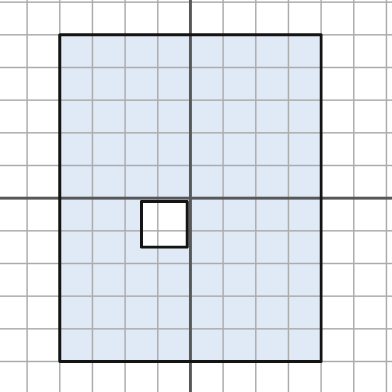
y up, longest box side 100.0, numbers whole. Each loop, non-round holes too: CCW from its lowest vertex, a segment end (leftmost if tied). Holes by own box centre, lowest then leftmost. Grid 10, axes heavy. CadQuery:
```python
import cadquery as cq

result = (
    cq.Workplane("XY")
    .moveTo(-40.0, -50.0)
    .lineTo(40.0, -50.0)
    .lineTo(40.0, 50.0)
    .lineTo(-40.0, 50.0)
    .close()
    .moveTo(-15.0, -15.0)
    .lineTo(-1.0, -15.0)
    .lineTo(-1.0, -1.0)
    .lineTo(-15.0, -1.0)
    .close()
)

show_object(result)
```